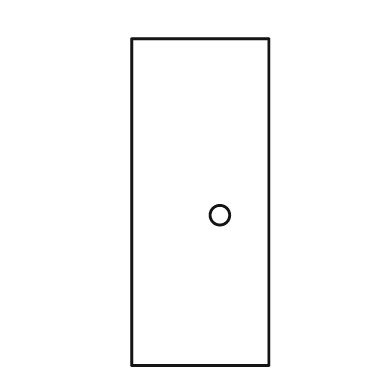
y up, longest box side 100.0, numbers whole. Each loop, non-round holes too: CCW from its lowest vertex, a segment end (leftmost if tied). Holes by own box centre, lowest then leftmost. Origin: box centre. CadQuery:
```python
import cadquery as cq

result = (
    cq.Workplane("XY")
    .moveTo(-21.0, -50.0)
    .lineTo(21.0, -50.0)
    .lineTo(21.0, 50.0)
    .lineTo(-21.0, 50.0)
    .close()
    .moveTo(6.0, -4.0)
    .circle(3.0)
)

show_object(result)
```